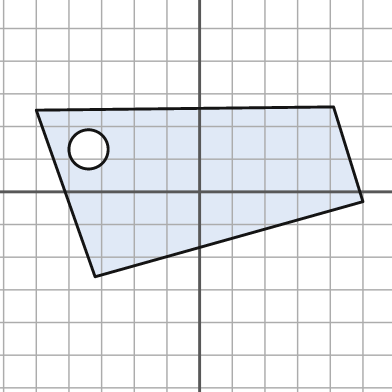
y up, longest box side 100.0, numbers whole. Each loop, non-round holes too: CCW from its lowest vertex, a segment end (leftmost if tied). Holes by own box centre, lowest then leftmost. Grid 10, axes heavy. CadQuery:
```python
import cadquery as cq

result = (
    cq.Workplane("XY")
    .moveTo(-32.0, -26.0)
    .lineTo(50.0, -3.0)
    .lineTo(41.0, 26.0)
    .lineTo(-50.0, 25.0)
    .close()
    .moveTo(-34.0, 13.0)
    .circle(6.0)
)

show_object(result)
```